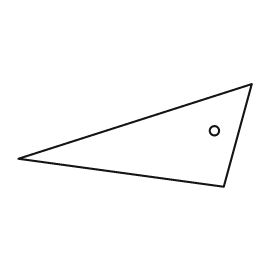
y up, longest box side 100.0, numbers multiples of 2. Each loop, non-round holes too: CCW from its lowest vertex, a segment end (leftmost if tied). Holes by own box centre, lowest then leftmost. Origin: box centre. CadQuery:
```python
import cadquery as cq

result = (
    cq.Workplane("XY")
    .moveTo(38.0, -22.0)
    .lineTo(50.0, 22.0)
    .lineTo(-50.0, -10.0)
    .close()
    .moveTo(34.0, 2.0)
    .circle(2.0)
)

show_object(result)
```